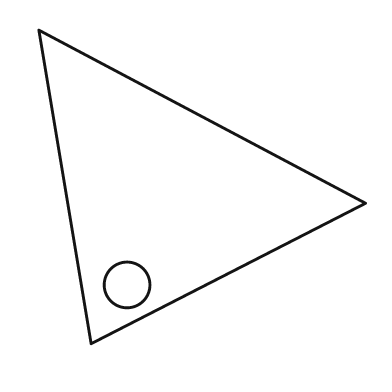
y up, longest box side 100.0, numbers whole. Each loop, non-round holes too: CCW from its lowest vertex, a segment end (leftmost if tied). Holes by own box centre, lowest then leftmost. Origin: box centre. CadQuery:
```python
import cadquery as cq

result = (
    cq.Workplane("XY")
    .moveTo(-34.0, -48.0)
    .lineTo(50.0, -5.0)
    .lineTo(-50.0, 48.0)
    .close()
    .moveTo(-23.0, -30.0)
    .circle(7.0)
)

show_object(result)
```